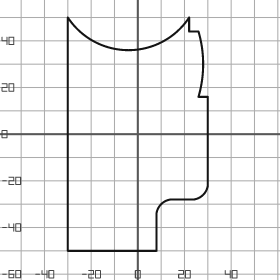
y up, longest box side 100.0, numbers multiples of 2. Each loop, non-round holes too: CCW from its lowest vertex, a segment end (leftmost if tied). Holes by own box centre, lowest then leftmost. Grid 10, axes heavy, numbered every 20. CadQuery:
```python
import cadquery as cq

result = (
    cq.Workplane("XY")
    .moveTo(-30.0, -50.0)
    .lineTo(8.0, -50.0)
    .lineTo(8.0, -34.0)
    .threePointArc((10.0, -30.0), (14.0, -28.0))
    .lineTo(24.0, -28.0)
    .threePointArc((28.0, -26.0), (30.0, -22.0))
    .lineTo(30.0, 16.0)
    .lineTo(26.0, 16.0)
    .threePointArc((28.0, 30.0), (26.0, 44.0))
    .lineTo(22.0, 44.0)
    .lineTo(22.0, 50.0)
    .threePointArc((-4.0, 36.0), (-30.0, 50.0))
    .close()
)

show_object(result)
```